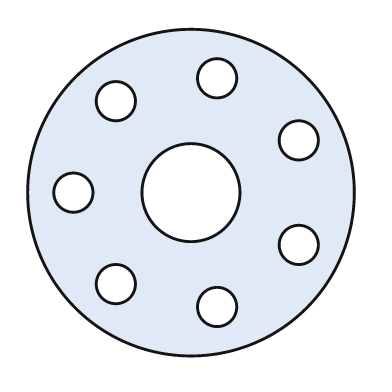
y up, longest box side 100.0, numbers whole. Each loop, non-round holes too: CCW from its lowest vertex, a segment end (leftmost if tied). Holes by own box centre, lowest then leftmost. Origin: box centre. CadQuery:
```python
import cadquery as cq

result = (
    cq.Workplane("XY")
    .moveTo(0.0, 0.0)
    .circle(50.0)
    .moveTo(8.0, -35.0)
    .circle(6.0)
    .moveTo(-23.0, -28.0)
    .circle(6.0)
    .moveTo(33.0, -16.0)
    .circle(6.0)
    .moveTo(-36.0, 0.0)
    .circle(6.0)
    .moveTo(0.0, 0.0)
    .circle(15.0)
    .moveTo(33.0, 16.0)
    .circle(6.0)
    .moveTo(-23.0, 28.0)
    .circle(6.0)
    .moveTo(8.0, 35.0)
    .circle(6.0)
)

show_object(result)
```